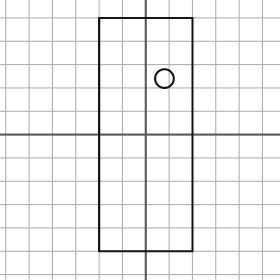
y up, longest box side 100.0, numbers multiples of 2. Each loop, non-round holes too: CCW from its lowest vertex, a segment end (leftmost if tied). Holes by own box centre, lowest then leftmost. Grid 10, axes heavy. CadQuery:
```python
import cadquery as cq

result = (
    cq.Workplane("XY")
    .moveTo(-20.0, -50.0)
    .lineTo(20.0, -50.0)
    .lineTo(20.0, 50.0)
    .lineTo(-20.0, 50.0)
    .close()
    .moveTo(8.0, 24.0)
    .circle(4.0)
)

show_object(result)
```